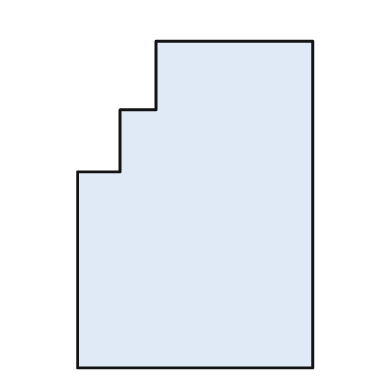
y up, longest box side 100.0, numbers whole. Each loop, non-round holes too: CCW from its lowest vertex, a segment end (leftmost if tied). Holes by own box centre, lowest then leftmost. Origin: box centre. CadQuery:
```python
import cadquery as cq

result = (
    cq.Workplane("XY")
    .moveTo(-36.0, -50.0)
    .lineTo(36.0, -50.0)
    .lineTo(36.0, 50.0)
    .lineTo(-12.0, 50.0)
    .lineTo(-12.0, 29.0)
    .lineTo(-23.0, 29.0)
    .lineTo(-23.0, 10.0)
    .lineTo(-36.0, 10.0)
    .close()
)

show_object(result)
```